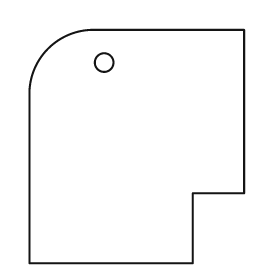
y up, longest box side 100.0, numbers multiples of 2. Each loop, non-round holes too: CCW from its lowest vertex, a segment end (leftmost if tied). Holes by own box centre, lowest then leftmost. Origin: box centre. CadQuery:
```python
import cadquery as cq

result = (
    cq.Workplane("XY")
    .moveTo(-46.0, -50.0)
    .lineTo(24.0, -50.0)
    .lineTo(24.0, -20.0)
    .lineTo(46.0, -20.0)
    .lineTo(46.0, 50.0)
    .lineTo(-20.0, 50.0)
    .threePointArc((-38.0, 42.0), (-46.0, 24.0))
    .close()
    .moveTo(-14.0, 36.0)
    .circle(4.0)
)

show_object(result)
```